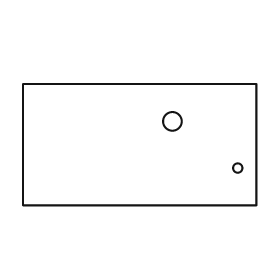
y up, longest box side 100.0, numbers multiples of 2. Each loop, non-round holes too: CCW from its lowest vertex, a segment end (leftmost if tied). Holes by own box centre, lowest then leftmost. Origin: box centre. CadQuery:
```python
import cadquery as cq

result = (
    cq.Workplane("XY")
    .moveTo(-50.0, -26.0)
    .lineTo(50.0, -26.0)
    .lineTo(50.0, 26.0)
    .lineTo(-50.0, 26.0)
    .close()
    .moveTo(42.0, -10.0)
    .circle(2.0)
    .moveTo(14.0, 10.0)
    .circle(4.0)
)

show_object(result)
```